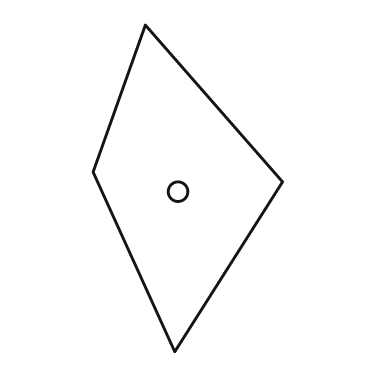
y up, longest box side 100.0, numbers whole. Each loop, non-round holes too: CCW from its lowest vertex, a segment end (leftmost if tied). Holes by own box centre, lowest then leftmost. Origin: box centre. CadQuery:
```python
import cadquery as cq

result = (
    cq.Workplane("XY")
    .moveTo(-4.0, -50.0)
    .lineTo(29.0, 2.0)
    .lineTo(-13.0, 50.0)
    .lineTo(-29.0, 5.0)
    .close()
    .moveTo(-3.0, -1.0)
    .circle(3.0)
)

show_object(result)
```